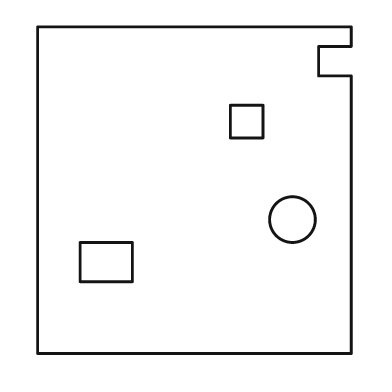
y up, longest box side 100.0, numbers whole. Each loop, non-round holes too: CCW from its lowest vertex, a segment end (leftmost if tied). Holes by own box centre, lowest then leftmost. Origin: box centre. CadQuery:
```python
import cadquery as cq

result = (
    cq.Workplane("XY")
    .moveTo(-48.0, -50.0)
    .lineTo(48.0, -50.0)
    .lineTo(48.0, 35.0)
    .lineTo(38.0, 35.0)
    .lineTo(38.0, 44.0)
    .lineTo(48.0, 44.0)
    .lineTo(48.0, 50.0)
    .lineTo(-48.0, 50.0)
    .close()
    .moveTo(-35.0, -28.0)
    .lineTo(-19.0, -28.0)
    .lineTo(-19.0, -16.0)
    .lineTo(-35.0, -16.0)
    .close()
    .moveTo(30.0, -9.0)
    .circle(7.0)
    .moveTo(11.0, 16.0)
    .lineTo(21.0, 16.0)
    .lineTo(21.0, 26.0)
    .lineTo(11.0, 26.0)
    .close()
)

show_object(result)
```